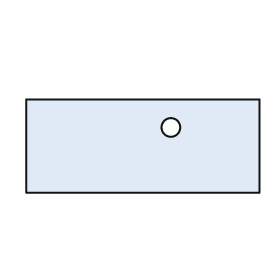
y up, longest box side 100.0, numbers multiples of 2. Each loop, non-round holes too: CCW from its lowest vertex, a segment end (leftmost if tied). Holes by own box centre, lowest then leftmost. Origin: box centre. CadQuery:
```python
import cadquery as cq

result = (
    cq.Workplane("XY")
    .moveTo(-50.0, -20.0)
    .lineTo(50.0, -20.0)
    .lineTo(50.0, 20.0)
    .lineTo(-50.0, 20.0)
    .close()
    .moveTo(12.0, 8.0)
    .circle(4.0)
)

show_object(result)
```